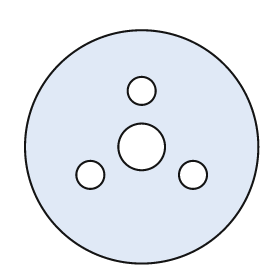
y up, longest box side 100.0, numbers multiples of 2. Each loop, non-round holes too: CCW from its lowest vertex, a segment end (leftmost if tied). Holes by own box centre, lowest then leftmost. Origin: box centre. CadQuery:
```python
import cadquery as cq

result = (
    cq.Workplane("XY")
    .moveTo(0.0, 0.0)
    .circle(50.0)
    .moveTo(-22.0, -12.0)
    .circle(6.0)
    .moveTo(22.0, -12.0)
    .circle(6.0)
    .moveTo(0.0, 0.0)
    .circle(10.0)
    .moveTo(0.0, 24.0)
    .circle(6.0)
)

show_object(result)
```